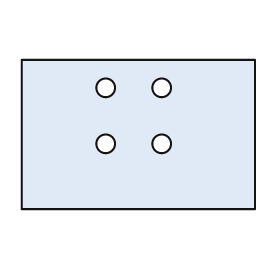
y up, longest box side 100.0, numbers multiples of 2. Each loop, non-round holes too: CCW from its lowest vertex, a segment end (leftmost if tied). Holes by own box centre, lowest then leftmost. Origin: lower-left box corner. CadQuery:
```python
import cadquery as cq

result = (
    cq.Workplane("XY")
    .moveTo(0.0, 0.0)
    .lineTo(100.0, 0.0)
    .lineTo(100.0, 64.0)
    .lineTo(0.0, 64.0)
    .close()
    .moveTo(36.0, 28.0)
    .circle(4.0)
    .moveTo(60.0, 28.0)
    .circle(4.0)
    .moveTo(36.0, 52.0)
    .circle(4.0)
    .moveTo(60.0, 52.0)
    .circle(4.0)
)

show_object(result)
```